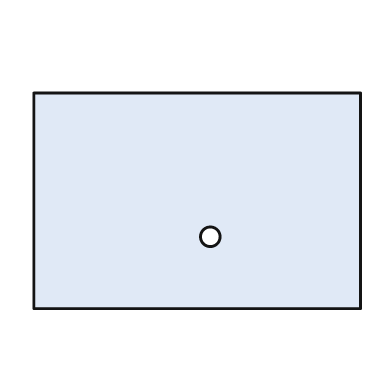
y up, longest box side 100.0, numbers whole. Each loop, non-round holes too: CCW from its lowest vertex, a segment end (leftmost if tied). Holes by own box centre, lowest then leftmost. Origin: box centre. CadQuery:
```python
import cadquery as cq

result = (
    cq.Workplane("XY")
    .moveTo(-50.0, -33.0)
    .lineTo(50.0, -33.0)
    .lineTo(50.0, 33.0)
    .lineTo(-50.0, 33.0)
    .close()
    .moveTo(4.0, -11.0)
    .circle(3.0)
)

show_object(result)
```